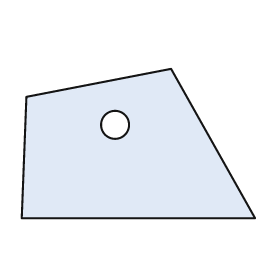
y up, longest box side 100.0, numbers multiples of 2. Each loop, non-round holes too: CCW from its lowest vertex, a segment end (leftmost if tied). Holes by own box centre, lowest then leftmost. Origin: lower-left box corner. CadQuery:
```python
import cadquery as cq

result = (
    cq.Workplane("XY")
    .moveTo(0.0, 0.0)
    .lineTo(100.0, 0.0)
    .lineTo(64.0, 64.0)
    .lineTo(2.0, 52.0)
    .close()
    .moveTo(40.0, 40.0)
    .circle(6.0)
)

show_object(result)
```